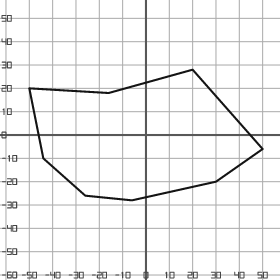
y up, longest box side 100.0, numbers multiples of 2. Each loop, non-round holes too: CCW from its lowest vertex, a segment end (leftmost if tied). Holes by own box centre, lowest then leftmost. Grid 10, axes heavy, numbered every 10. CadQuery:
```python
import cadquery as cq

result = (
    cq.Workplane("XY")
    .moveTo(-6.0, -28.0)
    .lineTo(30.0, -20.0)
    .lineTo(50.0, -6.0)
    .lineTo(20.0, 28.0)
    .lineTo(-16.0, 18.0)
    .lineTo(-50.0, 20.0)
    .lineTo(-44.0, -10.0)
    .lineTo(-26.0, -26.0)
    .close()
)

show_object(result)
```